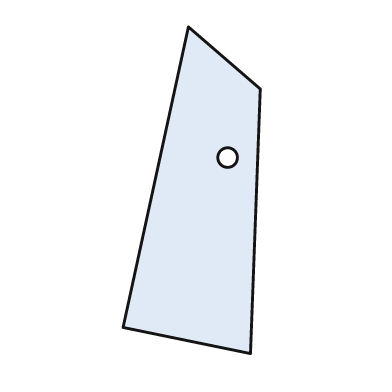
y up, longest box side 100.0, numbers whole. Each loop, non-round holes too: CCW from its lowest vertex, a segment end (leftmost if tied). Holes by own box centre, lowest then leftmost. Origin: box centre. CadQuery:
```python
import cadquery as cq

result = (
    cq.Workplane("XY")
    .moveTo(18.0, -50.0)
    .lineTo(21.0, 31.0)
    .lineTo(-1.0, 50.0)
    .lineTo(-21.0, -42.0)
    .close()
    .moveTo(11.0, 10.0)
    .circle(3.0)
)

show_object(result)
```